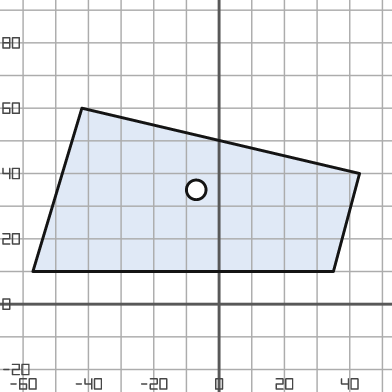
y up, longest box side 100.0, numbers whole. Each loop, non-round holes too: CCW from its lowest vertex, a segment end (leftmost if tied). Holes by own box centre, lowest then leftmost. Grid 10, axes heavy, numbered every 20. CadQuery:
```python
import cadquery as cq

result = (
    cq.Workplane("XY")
    .moveTo(-57.0, 10.0)
    .lineTo(35.0, 10.0)
    .lineTo(43.0, 40.0)
    .lineTo(-42.0, 60.0)
    .close()
    .moveTo(-7.0, 35.0)
    .circle(3.0)
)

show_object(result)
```